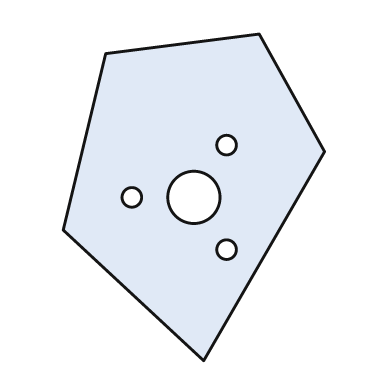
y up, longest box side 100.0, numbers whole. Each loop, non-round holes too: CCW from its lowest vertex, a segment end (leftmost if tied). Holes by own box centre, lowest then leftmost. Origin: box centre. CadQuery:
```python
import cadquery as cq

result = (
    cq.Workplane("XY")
    .moveTo(3.0, -50.0)
    .lineTo(40.0, 14.0)
    .lineTo(20.0, 50.0)
    .lineTo(-27.0, 44.0)
    .lineTo(-40.0, -10.0)
    .close()
    .moveTo(10.0, -16.0)
    .circle(3.0)
    .moveTo(-19.0, 0.0)
    .circle(3.0)
    .moveTo(0.0, 0.0)
    .circle(8.0)
    .moveTo(10.0, 16.0)
    .circle(3.0)
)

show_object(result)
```